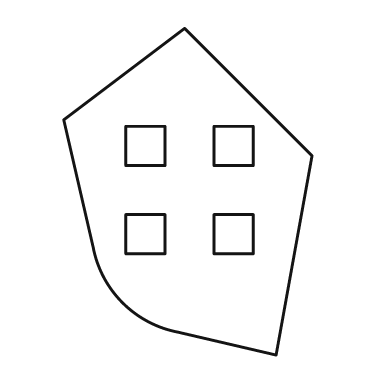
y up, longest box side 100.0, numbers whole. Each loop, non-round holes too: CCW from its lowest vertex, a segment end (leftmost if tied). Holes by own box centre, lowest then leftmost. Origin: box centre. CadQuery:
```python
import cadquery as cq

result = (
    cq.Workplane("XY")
    .moveTo(27.0, -50.0)
    .lineTo(38.0, 11.0)
    .lineTo(-1.0, 50.0)
    .lineTo(-38.0, 22.0)
    .lineTo(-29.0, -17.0)
    .threePointArc((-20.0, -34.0), (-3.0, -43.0))
    .close()
    .moveTo(-19.0, -19.0)
    .lineTo(-7.0, -19.0)
    .lineTo(-7.0, -7.0)
    .lineTo(-19.0, -7.0)
    .close()
    .moveTo(8.0, -19.0)
    .lineTo(20.0, -19.0)
    .lineTo(20.0, -7.0)
    .lineTo(8.0, -7.0)
    .close()
    .moveTo(-19.0, 8.0)
    .lineTo(-7.0, 8.0)
    .lineTo(-7.0, 20.0)
    .lineTo(-19.0, 20.0)
    .close()
    .moveTo(8.0, 8.0)
    .lineTo(20.0, 8.0)
    .lineTo(20.0, 20.0)
    .lineTo(8.0, 20.0)
    .close()
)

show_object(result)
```